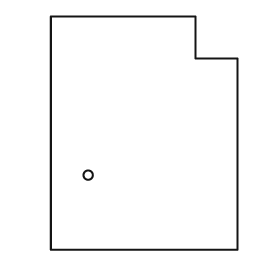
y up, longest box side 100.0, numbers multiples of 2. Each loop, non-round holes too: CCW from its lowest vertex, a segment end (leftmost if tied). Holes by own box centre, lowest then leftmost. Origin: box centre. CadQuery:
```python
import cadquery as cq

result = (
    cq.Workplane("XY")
    .moveTo(-40.0, -50.0)
    .lineTo(40.0, -50.0)
    .lineTo(40.0, 32.0)
    .lineTo(22.0, 32.0)
    .lineTo(22.0, 50.0)
    .lineTo(-40.0, 50.0)
    .close()
    .moveTo(-24.0, -18.0)
    .circle(2.0)
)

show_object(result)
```